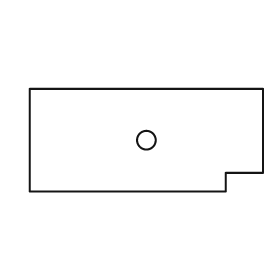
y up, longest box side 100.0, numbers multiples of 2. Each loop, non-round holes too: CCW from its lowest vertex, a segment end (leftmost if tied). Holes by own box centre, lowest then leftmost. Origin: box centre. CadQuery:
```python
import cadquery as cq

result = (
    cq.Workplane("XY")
    .moveTo(-50.0, -22.0)
    .lineTo(34.0, -22.0)
    .lineTo(34.0, -14.0)
    .lineTo(50.0, -14.0)
    .lineTo(50.0, 22.0)
    .lineTo(-50.0, 22.0)
    .close()
    .moveTo(0.0, 0.0)
    .circle(4.0)
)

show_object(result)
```